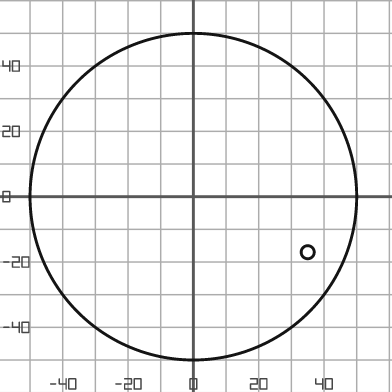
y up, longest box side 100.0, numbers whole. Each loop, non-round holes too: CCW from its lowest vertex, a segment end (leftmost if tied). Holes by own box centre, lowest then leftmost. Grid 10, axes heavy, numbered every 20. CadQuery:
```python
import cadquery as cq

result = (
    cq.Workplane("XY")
    .moveTo(0.0, 0.0)
    .circle(50.0)
    .moveTo(35.0, -17.0)
    .circle(2.0)
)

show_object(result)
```